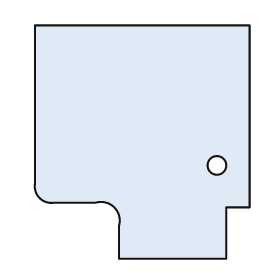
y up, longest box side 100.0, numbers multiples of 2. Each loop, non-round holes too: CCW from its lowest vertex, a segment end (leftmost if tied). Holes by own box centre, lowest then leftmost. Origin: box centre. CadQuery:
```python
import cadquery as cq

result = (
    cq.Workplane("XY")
    .moveTo(-10.0, -50.0)
    .lineTo(36.0, -50.0)
    .lineTo(36.0, -28.0)
    .lineTo(46.0, -28.0)
    .lineTo(46.0, 50.0)
    .lineTo(-46.0, 50.0)
    .lineTo(-46.0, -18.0)
    .threePointArc((-44.0, -24.0), (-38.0, -26.0))
    .lineTo(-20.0, -26.0)
    .threePointArc((-12.0, -28.0), (-10.0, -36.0))
    .close()
    .moveTo(32.0, -10.0)
    .circle(4.0)
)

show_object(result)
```